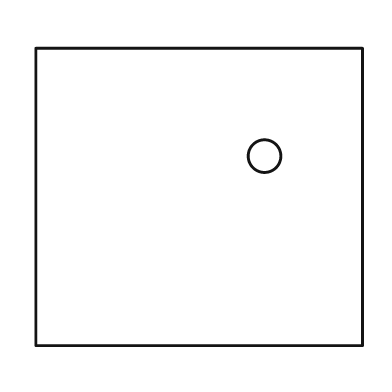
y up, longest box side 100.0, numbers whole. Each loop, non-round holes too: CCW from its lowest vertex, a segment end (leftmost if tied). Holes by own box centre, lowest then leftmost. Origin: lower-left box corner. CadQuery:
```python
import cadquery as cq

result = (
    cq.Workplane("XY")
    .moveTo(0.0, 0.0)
    .lineTo(100.0, 0.0)
    .lineTo(100.0, 91.0)
    .lineTo(0.0, 91.0)
    .close()
    .moveTo(70.0, 58.0)
    .circle(5.0)
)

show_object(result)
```